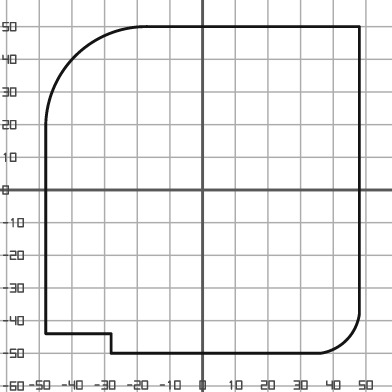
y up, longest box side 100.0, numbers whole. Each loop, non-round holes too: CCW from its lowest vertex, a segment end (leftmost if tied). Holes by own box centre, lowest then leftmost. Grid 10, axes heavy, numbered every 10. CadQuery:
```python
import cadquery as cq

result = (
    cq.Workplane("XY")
    .moveTo(-28.0, -50.0)
    .lineTo(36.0, -50.0)
    .threePointArc((44.0, -46.0), (48.0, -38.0))
    .lineTo(48.0, 50.0)
    .lineTo(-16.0, 50.0)
    .threePointArc((-39.0, 41.0), (-48.0, 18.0))
    .lineTo(-48.0, -44.0)
    .lineTo(-28.0, -44.0)
    .close()
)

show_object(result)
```